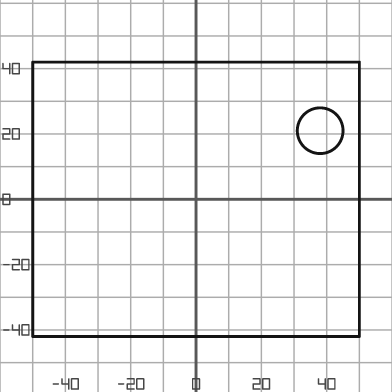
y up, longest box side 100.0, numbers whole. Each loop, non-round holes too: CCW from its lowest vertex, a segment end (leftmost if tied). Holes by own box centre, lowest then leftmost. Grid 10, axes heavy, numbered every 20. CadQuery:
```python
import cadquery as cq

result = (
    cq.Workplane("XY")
    .moveTo(-50.0, -42.0)
    .lineTo(50.0, -42.0)
    .lineTo(50.0, 42.0)
    .lineTo(-50.0, 42.0)
    .close()
    .moveTo(38.0, 21.0)
    .circle(7.0)
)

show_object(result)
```